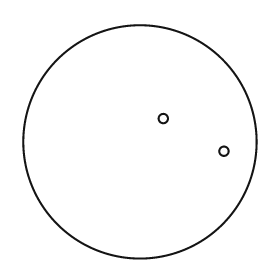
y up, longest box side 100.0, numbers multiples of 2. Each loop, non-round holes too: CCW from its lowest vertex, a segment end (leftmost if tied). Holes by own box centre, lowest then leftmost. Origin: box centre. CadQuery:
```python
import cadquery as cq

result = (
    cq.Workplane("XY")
    .moveTo(0.0, 0.0)
    .circle(50.0)
    .moveTo(36.0, -4.0)
    .circle(2.0)
    .moveTo(10.0, 10.0)
    .circle(2.0)
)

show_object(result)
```